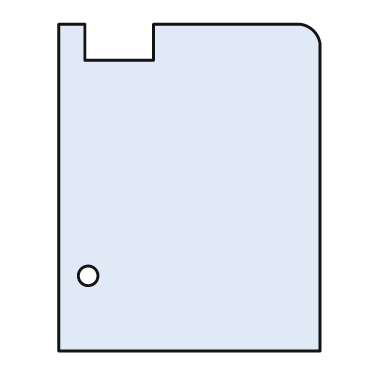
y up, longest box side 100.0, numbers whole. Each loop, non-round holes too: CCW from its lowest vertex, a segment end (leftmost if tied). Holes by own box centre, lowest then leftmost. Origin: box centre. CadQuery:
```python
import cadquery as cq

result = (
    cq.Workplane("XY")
    .moveTo(-40.0, -50.0)
    .lineTo(40.0, -50.0)
    .lineTo(40.0, 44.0)
    .threePointArc((38.0, 48.0), (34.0, 50.0))
    .lineTo(-11.0, 50.0)
    .lineTo(-11.0, 39.0)
    .lineTo(-32.0, 39.0)
    .lineTo(-32.0, 50.0)
    .lineTo(-40.0, 50.0)
    .close()
    .moveTo(-31.0, -27.0)
    .circle(3.0)
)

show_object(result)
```